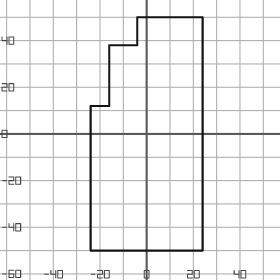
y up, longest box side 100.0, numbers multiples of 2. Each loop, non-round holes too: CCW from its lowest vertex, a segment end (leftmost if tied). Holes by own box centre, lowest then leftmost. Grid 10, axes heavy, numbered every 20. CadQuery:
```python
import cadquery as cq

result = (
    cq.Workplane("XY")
    .moveTo(-24.0, -50.0)
    .lineTo(24.0, -50.0)
    .lineTo(24.0, 50.0)
    .lineTo(-4.0, 50.0)
    .lineTo(-4.0, 38.0)
    .lineTo(-16.0, 38.0)
    .lineTo(-16.0, 12.0)
    .lineTo(-24.0, 12.0)
    .close()
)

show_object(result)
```